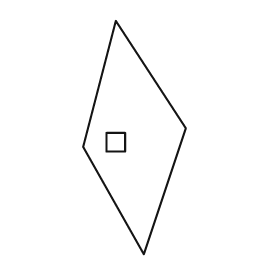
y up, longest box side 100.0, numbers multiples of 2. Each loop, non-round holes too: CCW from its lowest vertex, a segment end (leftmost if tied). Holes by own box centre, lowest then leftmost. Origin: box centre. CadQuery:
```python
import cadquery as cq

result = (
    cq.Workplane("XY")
    .moveTo(4.0, -50.0)
    .lineTo(22.0, 4.0)
    .lineTo(-8.0, 50.0)
    .lineTo(-22.0, -4.0)
    .close()
    .moveTo(-12.0, -6.0)
    .lineTo(-4.0, -6.0)
    .lineTo(-4.0, 2.0)
    .lineTo(-12.0, 2.0)
    .close()
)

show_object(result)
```